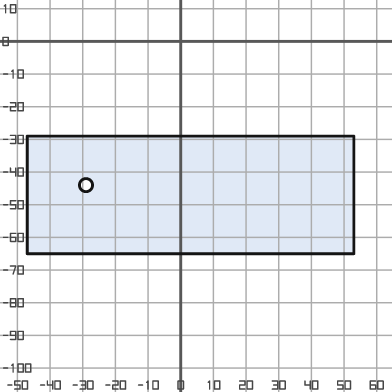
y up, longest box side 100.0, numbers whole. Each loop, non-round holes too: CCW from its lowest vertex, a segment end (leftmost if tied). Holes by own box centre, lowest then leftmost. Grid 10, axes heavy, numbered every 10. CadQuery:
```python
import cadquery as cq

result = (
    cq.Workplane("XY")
    .moveTo(-47.0, -65.0)
    .lineTo(53.0, -65.0)
    .lineTo(53.0, -29.0)
    .lineTo(-47.0, -29.0)
    .close()
    .moveTo(-29.0, -44.0)
    .circle(2.0)
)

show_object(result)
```